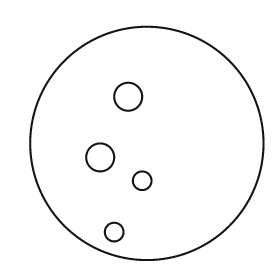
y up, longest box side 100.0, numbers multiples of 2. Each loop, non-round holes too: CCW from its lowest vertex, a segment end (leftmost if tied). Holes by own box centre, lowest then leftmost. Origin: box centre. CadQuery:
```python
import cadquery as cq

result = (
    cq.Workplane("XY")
    .moveTo(0.0, 0.0)
    .circle(50.0)
    .moveTo(-14.0, -38.0)
    .circle(4.0)
    .moveTo(-2.0, -16.0)
    .circle(4.0)
    .moveTo(-20.0, -6.0)
    .circle(6.0)
    .moveTo(-8.0, 20.0)
    .circle(6.0)
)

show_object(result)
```